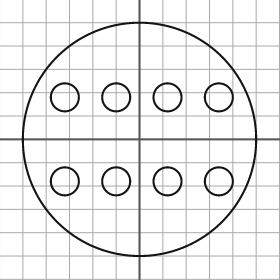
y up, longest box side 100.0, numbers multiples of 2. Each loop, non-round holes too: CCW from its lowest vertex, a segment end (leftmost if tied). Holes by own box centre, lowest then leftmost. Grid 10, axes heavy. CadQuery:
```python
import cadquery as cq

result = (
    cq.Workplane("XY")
    .moveTo(0.0, 0.0)
    .circle(50.0)
    .moveTo(-32.0, -18.0)
    .circle(6.0)
    .moveTo(-10.0, -18.0)
    .circle(6.0)
    .moveTo(12.0, -18.0)
    .circle(6.0)
    .moveTo(34.0, -18.0)
    .circle(6.0)
    .moveTo(-32.0, 18.0)
    .circle(6.0)
    .moveTo(-10.0, 18.0)
    .circle(6.0)
    .moveTo(12.0, 18.0)
    .circle(6.0)
    .moveTo(34.0, 18.0)
    .circle(6.0)
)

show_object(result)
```